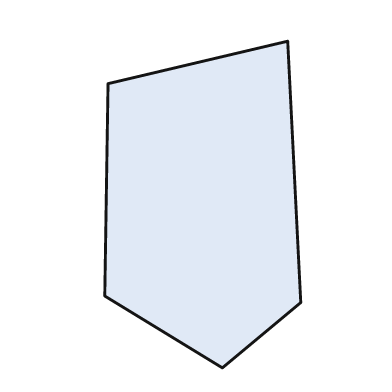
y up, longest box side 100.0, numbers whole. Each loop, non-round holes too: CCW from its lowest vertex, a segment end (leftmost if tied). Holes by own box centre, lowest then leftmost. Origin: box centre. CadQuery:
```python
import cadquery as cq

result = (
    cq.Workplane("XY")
    .moveTo(6.0, -50.0)
    .lineTo(30.0, -30.0)
    .lineTo(26.0, 50.0)
    .lineTo(-29.0, 37.0)
    .lineTo(-30.0, -28.0)
    .close()
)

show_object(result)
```